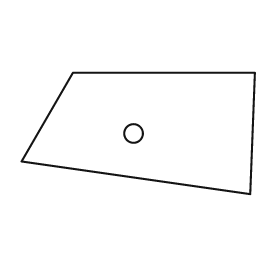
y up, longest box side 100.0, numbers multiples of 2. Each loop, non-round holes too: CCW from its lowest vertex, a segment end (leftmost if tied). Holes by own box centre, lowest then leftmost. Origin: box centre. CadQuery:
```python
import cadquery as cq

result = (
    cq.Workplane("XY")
    .moveTo(48.0, -26.0)
    .lineTo(50.0, 26.0)
    .lineTo(-28.0, 26.0)
    .lineTo(-50.0, -12.0)
    .close()
    .moveTo(-2.0, 0.0)
    .circle(4.0)
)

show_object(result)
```